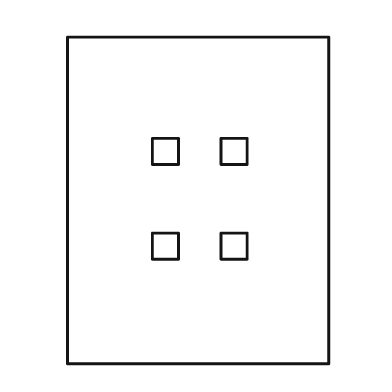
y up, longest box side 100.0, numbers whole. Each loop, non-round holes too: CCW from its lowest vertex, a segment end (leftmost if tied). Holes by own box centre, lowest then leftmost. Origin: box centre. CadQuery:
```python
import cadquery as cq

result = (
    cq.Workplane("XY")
    .moveTo(-40.0, -50.0)
    .lineTo(40.0, -50.0)
    .lineTo(40.0, 50.0)
    .lineTo(-40.0, 50.0)
    .close()
    .moveTo(-14.0, -18.0)
    .lineTo(-6.0, -18.0)
    .lineTo(-6.0, -10.0)
    .lineTo(-14.0, -10.0)
    .close()
    .moveTo(7.0, -18.0)
    .lineTo(15.0, -18.0)
    .lineTo(15.0, -10.0)
    .lineTo(7.0, -10.0)
    .close()
    .moveTo(-14.0, 11.0)
    .lineTo(-6.0, 11.0)
    .lineTo(-6.0, 19.0)
    .lineTo(-14.0, 19.0)
    .close()
    .moveTo(7.0, 11.0)
    .lineTo(15.0, 11.0)
    .lineTo(15.0, 19.0)
    .lineTo(7.0, 19.0)
    .close()
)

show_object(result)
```